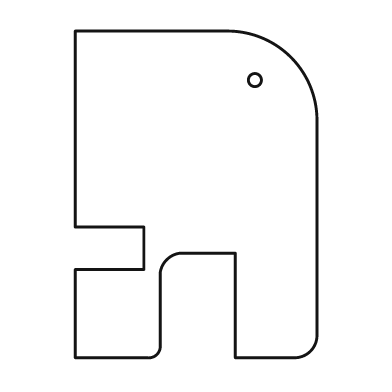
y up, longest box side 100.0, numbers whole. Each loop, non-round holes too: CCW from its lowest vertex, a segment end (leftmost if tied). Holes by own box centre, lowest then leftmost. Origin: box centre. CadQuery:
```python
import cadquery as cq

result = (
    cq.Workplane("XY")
    .moveTo(-37.0, -50.0)
    .lineTo(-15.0, -50.0)
    .threePointArc((-12.0, -49.0), (-11.0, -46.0))
    .lineTo(-11.0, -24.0)
    .threePointArc((-9.0, -20.0), (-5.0, -18.0))
    .lineTo(12.0, -18.0)
    .lineTo(12.0, -50.0)
    .lineTo(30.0, -50.0)
    .threePointArc((35.0, -48.0), (37.0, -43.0))
    .lineTo(37.0, 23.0)
    .threePointArc((29.0, 42.0), (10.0, 50.0))
    .lineTo(-37.0, 50.0)
    .lineTo(-37.0, -10.0)
    .lineTo(-16.0, -10.0)
    .lineTo(-16.0, -23.0)
    .lineTo(-37.0, -23.0)
    .close()
    .moveTo(18.0, 35.0)
    .circle(2.0)
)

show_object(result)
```